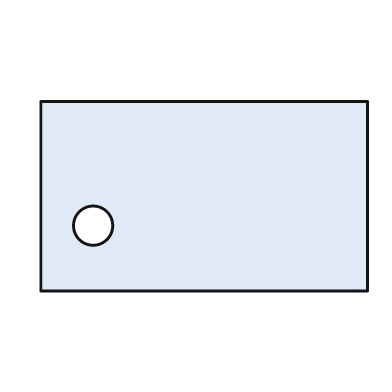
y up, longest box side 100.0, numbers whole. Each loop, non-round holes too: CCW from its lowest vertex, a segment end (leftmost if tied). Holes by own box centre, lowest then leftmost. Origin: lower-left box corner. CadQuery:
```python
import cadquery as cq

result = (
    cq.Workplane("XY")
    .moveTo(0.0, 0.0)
    .lineTo(100.0, 0.0)
    .lineTo(100.0, 58.0)
    .lineTo(0.0, 58.0)
    .close()
    .moveTo(16.0, 20.0)
    .circle(6.0)
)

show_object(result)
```